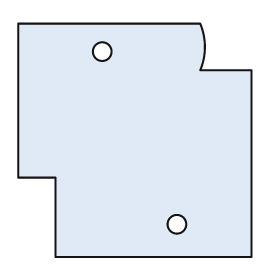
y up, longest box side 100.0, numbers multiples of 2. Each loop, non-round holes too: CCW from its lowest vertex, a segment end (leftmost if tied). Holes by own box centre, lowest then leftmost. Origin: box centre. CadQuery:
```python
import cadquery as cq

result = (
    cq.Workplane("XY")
    .moveTo(-34.0, -50.0)
    .lineTo(50.0, -50.0)
    .lineTo(50.0, 30.0)
    .lineTo(28.0, 30.0)
    .threePointArc((30.0, 40.0), (28.0, 50.0))
    .lineTo(-50.0, 50.0)
    .lineTo(-50.0, -16.0)
    .lineTo(-34.0, -16.0)
    .close()
    .moveTo(18.0, -36.0)
    .circle(4.0)
    .moveTo(-14.0, 38.0)
    .circle(4.0)
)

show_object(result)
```